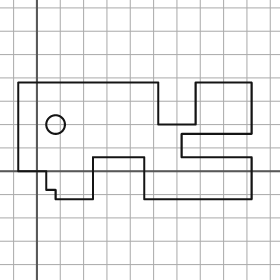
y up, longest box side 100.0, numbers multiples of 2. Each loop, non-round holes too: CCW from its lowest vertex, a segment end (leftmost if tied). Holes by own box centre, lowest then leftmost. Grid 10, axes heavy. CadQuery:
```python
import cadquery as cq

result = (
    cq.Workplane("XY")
    .moveTo(8.0, -12.0)
    .lineTo(24.0, -12.0)
    .lineTo(24.0, 6.0)
    .lineTo(46.0, 6.0)
    .lineTo(46.0, -12.0)
    .lineTo(92.0, -12.0)
    .lineTo(92.0, 6.0)
    .lineTo(62.0, 6.0)
    .lineTo(62.0, 16.0)
    .lineTo(92.0, 16.0)
    .lineTo(92.0, 38.0)
    .lineTo(68.0, 38.0)
    .lineTo(68.0, 20.0)
    .lineTo(52.0, 20.0)
    .lineTo(52.0, 38.0)
    .lineTo(-8.0, 38.0)
    .lineTo(-8.0, 0.0)
    .lineTo(4.0, 0.0)
    .lineTo(4.0, -8.0)
    .lineTo(8.0, -8.0)
    .close()
    .moveTo(8.0, 20.0)
    .circle(4.0)
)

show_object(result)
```